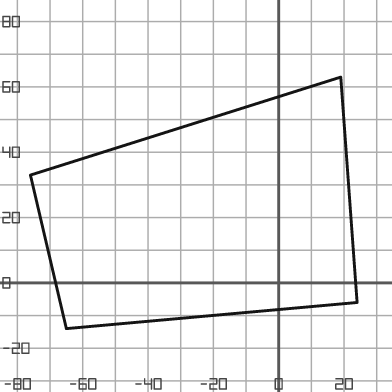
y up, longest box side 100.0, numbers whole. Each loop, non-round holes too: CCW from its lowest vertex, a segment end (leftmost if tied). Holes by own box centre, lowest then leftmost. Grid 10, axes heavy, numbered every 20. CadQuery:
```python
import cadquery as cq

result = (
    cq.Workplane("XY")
    .moveTo(-65.0, -14.0)
    .lineTo(24.0, -6.0)
    .lineTo(19.0, 63.0)
    .lineTo(-76.0, 33.0)
    .close()
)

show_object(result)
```